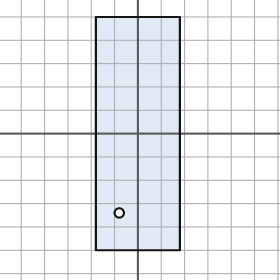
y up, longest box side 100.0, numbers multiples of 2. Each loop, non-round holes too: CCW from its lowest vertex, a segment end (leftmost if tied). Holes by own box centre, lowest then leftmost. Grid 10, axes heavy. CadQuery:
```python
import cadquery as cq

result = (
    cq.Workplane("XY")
    .moveTo(-18.0, -50.0)
    .lineTo(18.0, -50.0)
    .lineTo(18.0, 50.0)
    .lineTo(-18.0, 50.0)
    .close()
    .moveTo(-8.0, -34.0)
    .circle(2.0)
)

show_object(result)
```